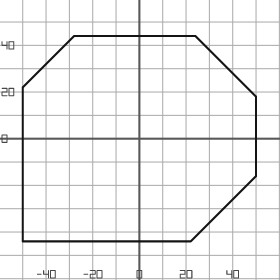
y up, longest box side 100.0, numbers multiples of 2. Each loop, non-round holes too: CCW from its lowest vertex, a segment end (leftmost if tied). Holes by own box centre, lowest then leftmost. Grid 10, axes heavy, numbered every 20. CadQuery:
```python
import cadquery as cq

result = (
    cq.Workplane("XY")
    .moveTo(-50.0, -44.0)
    .lineTo(22.0, -44.0)
    .lineTo(50.0, -16.0)
    .lineTo(50.0, 18.0)
    .lineTo(24.0, 44.0)
    .lineTo(-28.0, 44.0)
    .lineTo(-50.0, 22.0)
    .close()
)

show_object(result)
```